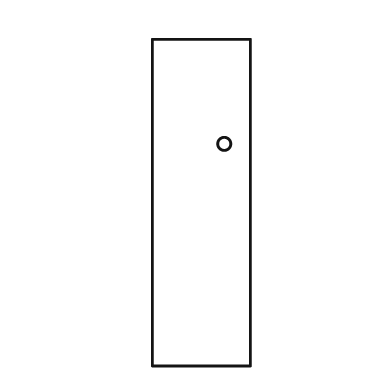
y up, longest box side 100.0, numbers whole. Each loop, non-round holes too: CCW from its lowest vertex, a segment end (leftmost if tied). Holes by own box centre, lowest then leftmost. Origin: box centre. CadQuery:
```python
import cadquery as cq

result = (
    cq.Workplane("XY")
    .moveTo(-15.0, -50.0)
    .lineTo(15.0, -50.0)
    .lineTo(15.0, 50.0)
    .lineTo(-15.0, 50.0)
    .close()
    .moveTo(7.0, 18.0)
    .circle(2.0)
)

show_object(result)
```